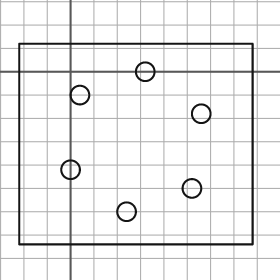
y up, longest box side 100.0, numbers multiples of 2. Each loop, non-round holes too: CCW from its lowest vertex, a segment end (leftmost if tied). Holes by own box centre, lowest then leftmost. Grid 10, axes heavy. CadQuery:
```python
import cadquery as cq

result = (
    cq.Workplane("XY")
    .moveTo(-22.0, -74.0)
    .lineTo(78.0, -74.0)
    .lineTo(78.0, 12.0)
    .lineTo(-22.0, 12.0)
    .close()
    .moveTo(24.0, -60.0)
    .circle(4.0)
    .moveTo(52.0, -50.0)
    .circle(4.0)
    .moveTo(0.0, -42.0)
    .circle(4.0)
    .moveTo(56.0, -18.0)
    .circle(4.0)
    .moveTo(4.0, -10.0)
    .circle(4.0)
    .moveTo(32.0, 0.0)
    .circle(4.0)
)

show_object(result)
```